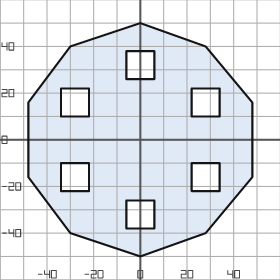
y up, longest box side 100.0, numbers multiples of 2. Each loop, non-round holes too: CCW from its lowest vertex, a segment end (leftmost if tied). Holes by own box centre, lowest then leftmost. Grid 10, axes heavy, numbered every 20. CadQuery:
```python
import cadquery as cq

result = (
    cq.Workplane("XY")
    .moveTo(0.0, -50.0)
    .lineTo(28.0, -40.0)
    .lineTo(48.0, -16.0)
    .lineTo(48.0, 16.0)
    .lineTo(28.0, 40.0)
    .lineTo(0.0, 50.0)
    .lineTo(-30.0, 40.0)
    .lineTo(-48.0, 16.0)
    .lineTo(-48.0, -16.0)
    .lineTo(-30.0, -40.0)
    .close()
    .moveTo(-6.0, -38.0)
    .lineTo(6.0, -38.0)
    .lineTo(6.0, -26.0)
    .lineTo(-6.0, -26.0)
    .close()
    .moveTo(-34.0, -22.0)
    .lineTo(-22.0, -22.0)
    .lineTo(-22.0, -10.0)
    .lineTo(-34.0, -10.0)
    .close()
    .moveTo(22.0, -22.0)
    .lineTo(34.0, -22.0)
    .lineTo(34.0, -10.0)
    .lineTo(22.0, -10.0)
    .close()
    .moveTo(-34.0, 10.0)
    .lineTo(-22.0, 10.0)
    .lineTo(-22.0, 22.0)
    .lineTo(-34.0, 22.0)
    .close()
    .moveTo(22.0, 10.0)
    .lineTo(34.0, 10.0)
    .lineTo(34.0, 22.0)
    .lineTo(22.0, 22.0)
    .close()
    .moveTo(-6.0, 26.0)
    .lineTo(6.0, 26.0)
    .lineTo(6.0, 38.0)
    .lineTo(-6.0, 38.0)
    .close()
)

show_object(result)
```